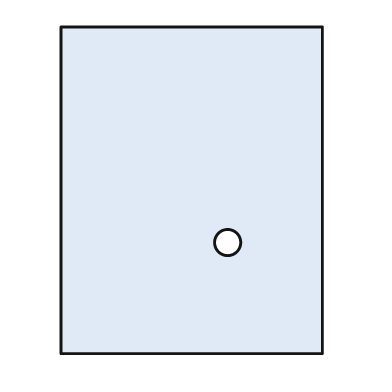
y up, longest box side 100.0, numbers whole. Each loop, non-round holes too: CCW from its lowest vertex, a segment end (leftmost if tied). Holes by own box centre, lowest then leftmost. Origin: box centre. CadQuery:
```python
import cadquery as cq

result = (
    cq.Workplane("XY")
    .moveTo(-40.0, -50.0)
    .lineTo(40.0, -50.0)
    .lineTo(40.0, 50.0)
    .lineTo(-40.0, 50.0)
    .close()
    .moveTo(11.0, -16.0)
    .circle(4.0)
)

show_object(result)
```